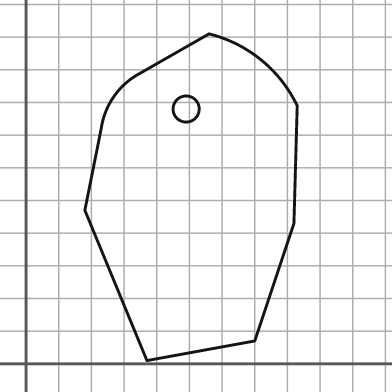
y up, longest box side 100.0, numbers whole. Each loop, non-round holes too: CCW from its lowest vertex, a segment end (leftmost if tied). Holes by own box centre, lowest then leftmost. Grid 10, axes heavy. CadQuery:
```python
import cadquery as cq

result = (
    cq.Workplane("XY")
    .moveTo(37.0, 1.0)
    .lineTo(70.0, 7.0)
    .lineTo(82.0, 43.0)
    .lineTo(83.0, 79.0)
    .threePointArc((72.0, 93.0), (56.0, 101.0))
    .lineTo(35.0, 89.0)
    .threePointArc((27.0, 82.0), (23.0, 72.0))
    .lineTo(18.0, 47.0)
    .close()
    .moveTo(49.0, 78.0)
    .circle(4.0)
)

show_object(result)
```